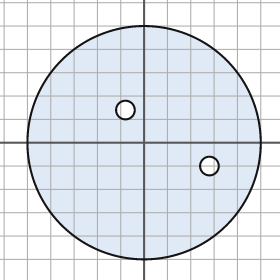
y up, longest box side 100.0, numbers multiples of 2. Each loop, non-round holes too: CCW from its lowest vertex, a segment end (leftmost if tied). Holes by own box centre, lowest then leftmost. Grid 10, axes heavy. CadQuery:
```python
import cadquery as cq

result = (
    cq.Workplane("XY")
    .moveTo(0.0, 0.0)
    .circle(50.0)
    .moveTo(28.0, -10.0)
    .circle(4.0)
    .moveTo(-8.0, 14.0)
    .circle(4.0)
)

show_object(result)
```